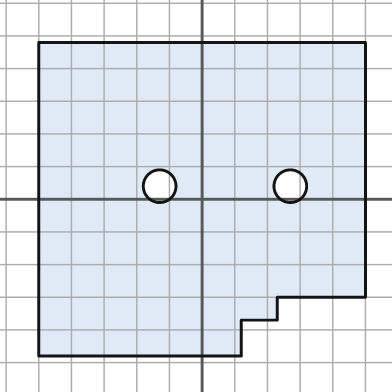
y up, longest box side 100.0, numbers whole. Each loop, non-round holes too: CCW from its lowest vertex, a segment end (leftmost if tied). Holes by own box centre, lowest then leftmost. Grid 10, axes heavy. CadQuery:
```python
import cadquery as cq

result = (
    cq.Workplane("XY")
    .moveTo(-50.0, -48.0)
    .lineTo(12.0, -48.0)
    .lineTo(12.0, -37.0)
    .lineTo(23.0, -37.0)
    .lineTo(23.0, -30.0)
    .lineTo(50.0, -30.0)
    .lineTo(50.0, 48.0)
    .lineTo(-50.0, 48.0)
    .close()
    .moveTo(-13.0, 4.0)
    .circle(5.0)
    .moveTo(27.0, 4.0)
    .circle(5.0)
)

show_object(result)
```